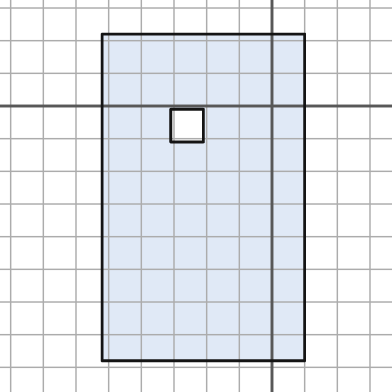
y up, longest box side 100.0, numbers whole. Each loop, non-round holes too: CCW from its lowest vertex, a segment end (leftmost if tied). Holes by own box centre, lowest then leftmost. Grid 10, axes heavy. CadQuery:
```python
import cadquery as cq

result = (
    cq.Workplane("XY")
    .moveTo(-52.0, -78.0)
    .lineTo(10.0, -78.0)
    .lineTo(10.0, 22.0)
    .lineTo(-52.0, 22.0)
    .close()
    .moveTo(-31.0, -11.0)
    .lineTo(-21.0, -11.0)
    .lineTo(-21.0, -1.0)
    .lineTo(-31.0, -1.0)
    .close()
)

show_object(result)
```